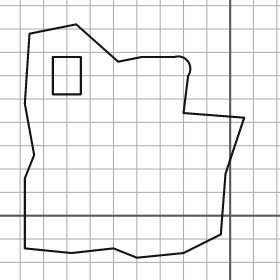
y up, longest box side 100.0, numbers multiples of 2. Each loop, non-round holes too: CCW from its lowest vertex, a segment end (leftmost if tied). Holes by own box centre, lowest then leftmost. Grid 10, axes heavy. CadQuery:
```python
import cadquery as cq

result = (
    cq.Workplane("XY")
    .moveTo(-40.0, -18.0)
    .lineTo(-20.0, -16.0)
    .lineTo(-4.0, -8.0)
    .lineTo(-2.0, 18.0)
    .lineTo(6.0, 42.0)
    .lineTo(-20.0, 44.0)
    .lineTo(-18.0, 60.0)
    .threePointArc((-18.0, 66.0), (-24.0, 68.0))
    .lineTo(-38.0, 68.0)
    .lineTo(-48.0, 66.0)
    .lineTo(-66.0, 82.0)
    .lineTo(-86.0, 78.0)
    .lineTo(-88.0, 48.0)
    .lineTo(-84.0, 26.0)
    .lineTo(-88.0, 16.0)
    .lineTo(-88.0, -14.0)
    .lineTo(-68.0, -16.0)
    .lineTo(-50.0, -14.0)
    .close()
    .moveTo(-76.0, 52.0)
    .lineTo(-64.0, 52.0)
    .lineTo(-64.0, 68.0)
    .lineTo(-76.0, 68.0)
    .close()
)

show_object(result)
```